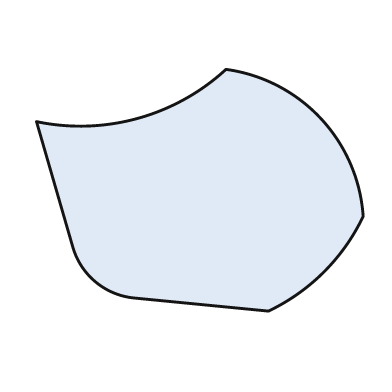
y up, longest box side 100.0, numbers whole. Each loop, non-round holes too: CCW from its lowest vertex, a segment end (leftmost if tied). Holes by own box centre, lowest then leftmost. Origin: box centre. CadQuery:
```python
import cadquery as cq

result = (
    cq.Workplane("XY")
    .moveTo(21.0, -37.0)
    .threePointArc((38.0, -25.0), (50.0, -8.0))
    .threePointArc((37.0, 22.0), (8.0, 37.0))
    .threePointArc((-19.0, 22.0), (-50.0, 21.0))
    .lineTo(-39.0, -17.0)
    .threePointArc((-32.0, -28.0), (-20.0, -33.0))
    .close()
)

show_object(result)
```